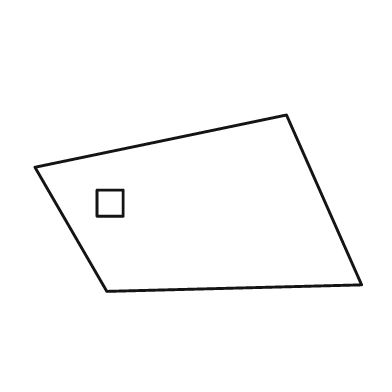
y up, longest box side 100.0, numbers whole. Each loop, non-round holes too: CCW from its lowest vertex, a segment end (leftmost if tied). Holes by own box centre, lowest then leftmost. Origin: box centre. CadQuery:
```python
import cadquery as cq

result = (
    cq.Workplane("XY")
    .moveTo(-28.0, -27.0)
    .lineTo(50.0, -25.0)
    .lineTo(27.0, 27.0)
    .lineTo(-50.0, 11.0)
    .close()
    .moveTo(-31.0, -4.0)
    .lineTo(-23.0, -4.0)
    .lineTo(-23.0, 4.0)
    .lineTo(-31.0, 4.0)
    .close()
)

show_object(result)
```